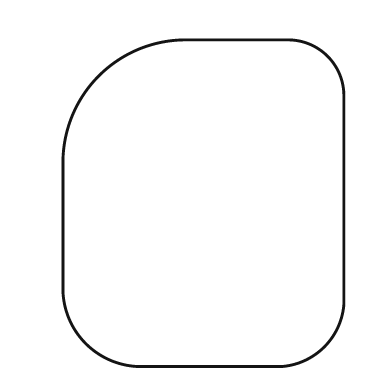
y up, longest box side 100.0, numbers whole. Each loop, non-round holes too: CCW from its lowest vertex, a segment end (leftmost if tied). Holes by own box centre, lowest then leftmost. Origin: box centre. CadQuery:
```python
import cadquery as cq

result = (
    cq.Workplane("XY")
    .moveTo(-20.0, -50.0)
    .lineTo(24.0, -50.0)
    .threePointArc((37.0, -44.0), (43.0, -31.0))
    .lineTo(43.0, 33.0)
    .threePointArc((38.0, 45.0), (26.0, 50.0))
    .lineTo(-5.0, 50.0)
    .threePointArc((-32.0, 39.0), (-43.0, 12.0))
    .lineTo(-43.0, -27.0)
    .threePointArc((-36.0, -43.0), (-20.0, -50.0))
    .close()
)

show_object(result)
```